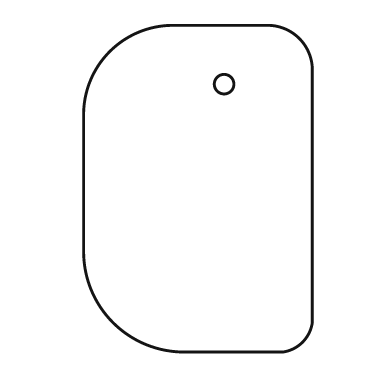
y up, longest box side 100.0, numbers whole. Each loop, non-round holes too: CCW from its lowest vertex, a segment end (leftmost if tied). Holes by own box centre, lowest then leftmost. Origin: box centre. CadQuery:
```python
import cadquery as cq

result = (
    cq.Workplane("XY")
    .moveTo(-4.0, -50.0)
    .lineTo(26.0, -50.0)
    .threePointArc((32.0, -47.0), (35.0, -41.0))
    .lineTo(35.0, 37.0)
    .threePointArc((31.0, 46.0), (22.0, 50.0))
    .lineTo(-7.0, 50.0)
    .threePointArc((-27.0, 42.0), (-35.0, 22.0))
    .lineTo(-35.0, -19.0)
    .threePointArc((-26.0, -41.0), (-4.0, -50.0))
    .close()
    .moveTo(8.0, 32.0)
    .circle(3.0)
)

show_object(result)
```